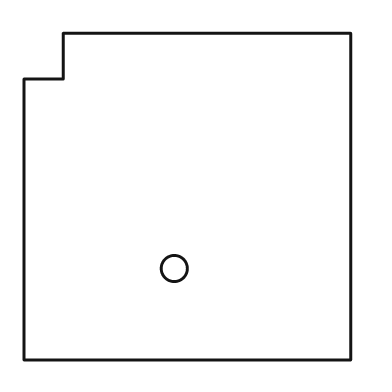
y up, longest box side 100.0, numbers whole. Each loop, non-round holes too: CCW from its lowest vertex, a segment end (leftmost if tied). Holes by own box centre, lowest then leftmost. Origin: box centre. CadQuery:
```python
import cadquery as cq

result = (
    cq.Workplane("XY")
    .moveTo(-50.0, -50.0)
    .lineTo(50.0, -50.0)
    .lineTo(50.0, 50.0)
    .lineTo(-38.0, 50.0)
    .lineTo(-38.0, 36.0)
    .lineTo(-50.0, 36.0)
    .close()
    .moveTo(-4.0, -22.0)
    .circle(4.0)
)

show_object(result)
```